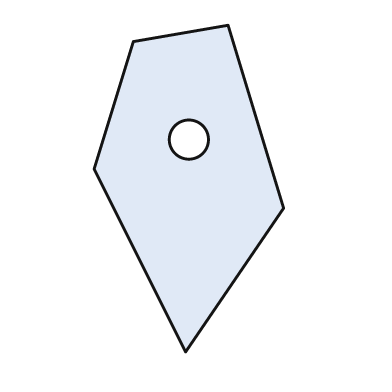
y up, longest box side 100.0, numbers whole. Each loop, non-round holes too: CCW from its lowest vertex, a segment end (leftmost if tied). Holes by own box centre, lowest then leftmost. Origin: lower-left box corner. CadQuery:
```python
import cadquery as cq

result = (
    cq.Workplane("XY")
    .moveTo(28.0, 0.0)
    .lineTo(58.0, 44.0)
    .lineTo(41.0, 100.0)
    .lineTo(12.0, 95.0)
    .lineTo(0.0, 56.0)
    .close()
    .moveTo(29.0, 65.0)
    .circle(6.0)
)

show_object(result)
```